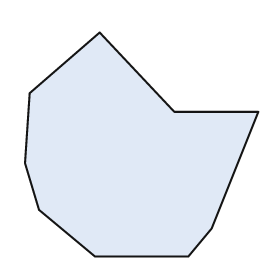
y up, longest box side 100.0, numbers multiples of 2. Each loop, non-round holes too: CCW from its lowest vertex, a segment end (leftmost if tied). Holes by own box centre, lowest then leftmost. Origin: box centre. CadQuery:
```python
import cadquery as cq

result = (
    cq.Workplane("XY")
    .moveTo(-20.0, -48.0)
    .lineTo(20.0, -48.0)
    .lineTo(30.0, -36.0)
    .lineTo(50.0, 14.0)
    .lineTo(14.0, 14.0)
    .lineTo(-18.0, 48.0)
    .lineTo(-48.0, 22.0)
    .lineTo(-50.0, -8.0)
    .lineTo(-44.0, -28.0)
    .close()
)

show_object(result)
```